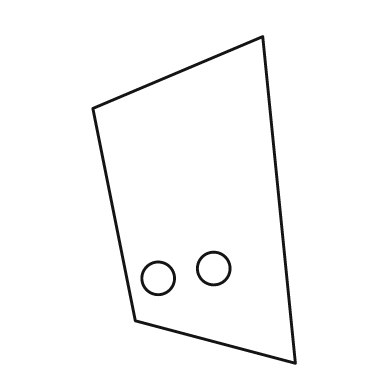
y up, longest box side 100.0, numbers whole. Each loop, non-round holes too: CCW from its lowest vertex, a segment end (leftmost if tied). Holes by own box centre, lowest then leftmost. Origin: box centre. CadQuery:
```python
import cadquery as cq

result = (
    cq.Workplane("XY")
    .moveTo(31.0, -50.0)
    .lineTo(21.0, 50.0)
    .lineTo(-31.0, 28.0)
    .lineTo(-18.0, -37.0)
    .close()
    .moveTo(-11.0, -24.0)
    .circle(5.0)
    .moveTo(6.0, -21.0)
    .circle(5.0)
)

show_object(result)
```